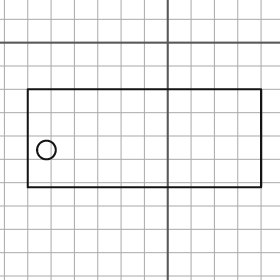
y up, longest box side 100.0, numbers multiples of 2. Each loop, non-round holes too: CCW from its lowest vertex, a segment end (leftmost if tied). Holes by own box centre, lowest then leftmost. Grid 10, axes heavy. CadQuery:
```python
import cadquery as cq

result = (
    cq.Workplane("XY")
    .moveTo(-60.0, -62.0)
    .lineTo(40.0, -62.0)
    .lineTo(40.0, -20.0)
    .lineTo(-60.0, -20.0)
    .close()
    .moveTo(-52.0, -46.0)
    .circle(4.0)
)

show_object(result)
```